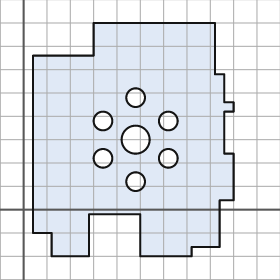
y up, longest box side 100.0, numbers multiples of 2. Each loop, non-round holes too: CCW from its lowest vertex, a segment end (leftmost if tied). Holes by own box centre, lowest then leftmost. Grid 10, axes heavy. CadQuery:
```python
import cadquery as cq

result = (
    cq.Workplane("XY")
    .moveTo(12.0, -20.0)
    .lineTo(28.0, -20.0)
    .lineTo(28.0, -2.0)
    .lineTo(50.0, -2.0)
    .lineTo(50.0, -20.0)
    .lineTo(72.0, -20.0)
    .lineTo(72.0, -16.0)
    .lineTo(84.0, -16.0)
    .lineTo(84.0, 4.0)
    .lineTo(90.0, 4.0)
    .lineTo(90.0, 24.0)
    .lineTo(86.0, 24.0)
    .lineTo(86.0, 42.0)
    .lineTo(90.0, 42.0)
    .lineTo(90.0, 46.0)
    .lineTo(86.0, 46.0)
    .lineTo(86.0, 58.0)
    .lineTo(82.0, 58.0)
    .lineTo(82.0, 80.0)
    .lineTo(30.0, 80.0)
    .lineTo(30.0, 66.0)
    .lineTo(4.0, 66.0)
    .lineTo(4.0, -10.0)
    .lineTo(12.0, -10.0)
    .close()
    .moveTo(48.0, 12.0)
    .circle(4.0)
    .moveTo(34.0, 22.0)
    .circle(4.0)
    .moveTo(62.0, 22.0)
    .circle(4.0)
    .moveTo(48.0, 30.0)
    .circle(6.0)
    .moveTo(34.0, 38.0)
    .circle(4.0)
    .moveTo(62.0, 38.0)
    .circle(4.0)
    .moveTo(48.0, 48.0)
    .circle(4.0)
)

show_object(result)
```